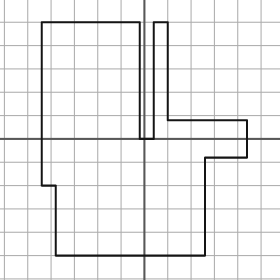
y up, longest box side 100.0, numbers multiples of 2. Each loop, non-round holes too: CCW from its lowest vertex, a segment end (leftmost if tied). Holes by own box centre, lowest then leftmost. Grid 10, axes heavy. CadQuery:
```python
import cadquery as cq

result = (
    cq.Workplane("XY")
    .moveTo(-38.0, -50.0)
    .lineTo(26.0, -50.0)
    .lineTo(26.0, -8.0)
    .lineTo(44.0, -8.0)
    .lineTo(44.0, 8.0)
    .lineTo(10.0, 8.0)
    .lineTo(10.0, 50.0)
    .lineTo(4.0, 50.0)
    .lineTo(4.0, 0.0)
    .lineTo(-2.0, 0.0)
    .lineTo(-2.0, 50.0)
    .lineTo(-44.0, 50.0)
    .lineTo(-44.0, -20.0)
    .lineTo(-38.0, -20.0)
    .close()
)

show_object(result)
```